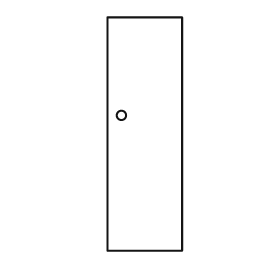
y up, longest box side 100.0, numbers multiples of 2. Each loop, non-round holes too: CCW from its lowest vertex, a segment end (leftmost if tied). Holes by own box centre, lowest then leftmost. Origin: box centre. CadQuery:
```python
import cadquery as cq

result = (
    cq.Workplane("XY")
    .moveTo(-16.0, -50.0)
    .lineTo(16.0, -50.0)
    .lineTo(16.0, 50.0)
    .lineTo(-16.0, 50.0)
    .close()
    .moveTo(-10.0, 8.0)
    .circle(2.0)
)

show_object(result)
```